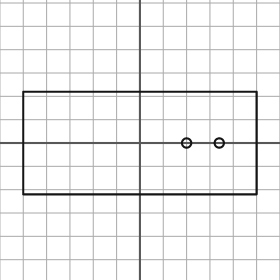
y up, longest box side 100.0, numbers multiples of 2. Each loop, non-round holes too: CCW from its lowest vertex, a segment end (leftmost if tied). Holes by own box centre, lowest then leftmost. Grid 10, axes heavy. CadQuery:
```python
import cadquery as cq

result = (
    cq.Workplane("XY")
    .moveTo(-50.0, -22.0)
    .lineTo(50.0, -22.0)
    .lineTo(50.0, 22.0)
    .lineTo(-50.0, 22.0)
    .close()
    .moveTo(20.0, 0.0)
    .circle(2.0)
    .moveTo(34.0, 0.0)
    .circle(2.0)
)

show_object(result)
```